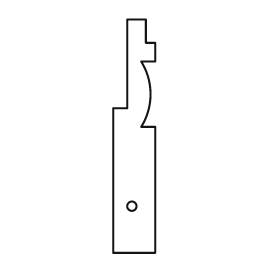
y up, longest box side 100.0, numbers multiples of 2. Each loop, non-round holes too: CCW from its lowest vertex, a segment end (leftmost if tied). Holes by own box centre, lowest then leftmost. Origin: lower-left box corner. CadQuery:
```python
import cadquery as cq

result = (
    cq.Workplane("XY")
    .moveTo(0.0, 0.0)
    .lineTo(18.0, 0.0)
    .lineTo(18.0, 54.0)
    .lineTo(12.0, 54.0)
    .threePointArc((16.0, 68.0), (12.0, 82.0))
    .lineTo(18.0, 82.0)
    .lineTo(18.0, 90.0)
    .lineTo(14.0, 90.0)
    .lineTo(14.0, 100.0)
    .lineTo(6.0, 100.0)
    .lineTo(6.0, 62.0)
    .lineTo(0.0, 62.0)
    .close()
    .moveTo(8.0, 20.0)
    .circle(2.0)
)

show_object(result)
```